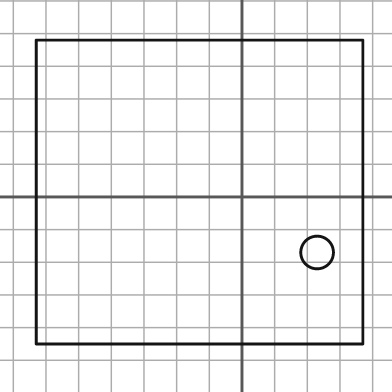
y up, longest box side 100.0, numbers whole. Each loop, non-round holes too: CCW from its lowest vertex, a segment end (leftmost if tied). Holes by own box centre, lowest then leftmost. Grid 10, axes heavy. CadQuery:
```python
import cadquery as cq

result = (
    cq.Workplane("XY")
    .moveTo(-63.0, -45.0)
    .lineTo(37.0, -45.0)
    .lineTo(37.0, 48.0)
    .lineTo(-63.0, 48.0)
    .close()
    .moveTo(23.0, -17.0)
    .circle(5.0)
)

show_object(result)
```